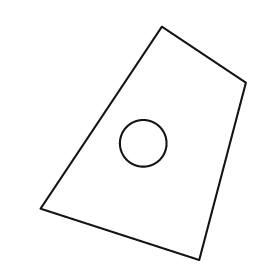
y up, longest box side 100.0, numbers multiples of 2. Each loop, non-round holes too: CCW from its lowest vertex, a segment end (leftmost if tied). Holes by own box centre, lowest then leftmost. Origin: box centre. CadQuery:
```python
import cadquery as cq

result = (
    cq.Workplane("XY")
    .moveTo(24.0, -50.0)
    .lineTo(44.0, 26.0)
    .lineTo(8.0, 50.0)
    .lineTo(-44.0, -28.0)
    .close()
    .moveTo(0.0, 0.0)
    .circle(10.0)
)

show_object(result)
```